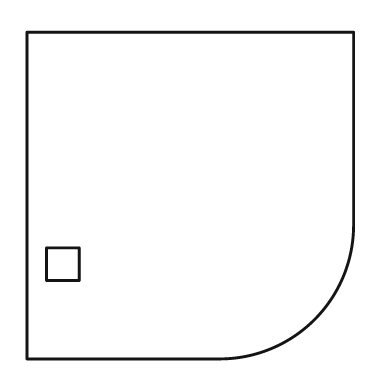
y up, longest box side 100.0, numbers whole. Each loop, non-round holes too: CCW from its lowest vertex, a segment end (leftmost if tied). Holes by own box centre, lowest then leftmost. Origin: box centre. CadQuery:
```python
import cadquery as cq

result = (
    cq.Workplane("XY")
    .moveTo(-50.0, -50.0)
    .lineTo(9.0, -50.0)
    .threePointArc((38.0, -38.0), (50.0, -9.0))
    .lineTo(50.0, 50.0)
    .lineTo(-50.0, 50.0)
    .close()
    .moveTo(-44.0, -26.0)
    .lineTo(-34.0, -26.0)
    .lineTo(-34.0, -16.0)
    .lineTo(-44.0, -16.0)
    .close()
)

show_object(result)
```